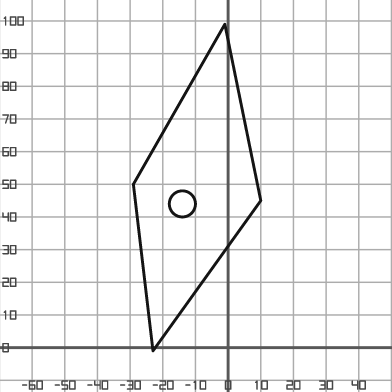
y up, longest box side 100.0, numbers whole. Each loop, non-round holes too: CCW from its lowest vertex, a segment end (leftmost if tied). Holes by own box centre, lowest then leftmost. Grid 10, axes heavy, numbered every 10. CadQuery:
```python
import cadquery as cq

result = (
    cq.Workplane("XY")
    .moveTo(-23.0, -1.0)
    .lineTo(10.0, 45.0)
    .lineTo(-1.0, 99.0)
    .lineTo(-29.0, 50.0)
    .close()
    .moveTo(-14.0, 44.0)
    .circle(4.0)
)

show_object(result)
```